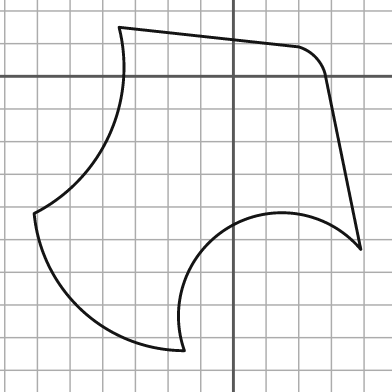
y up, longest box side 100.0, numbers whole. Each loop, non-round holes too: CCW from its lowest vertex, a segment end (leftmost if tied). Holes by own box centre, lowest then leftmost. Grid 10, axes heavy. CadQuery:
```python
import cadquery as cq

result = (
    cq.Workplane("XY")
    .moveTo(-15.0, -84.0)
    .threePointArc((-1.0, -46.0), (39.0, -53.0))
    .lineTo(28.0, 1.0)
    .threePointArc((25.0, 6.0), (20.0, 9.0))
    .lineTo(-35.0, 15.0)
    .threePointArc((-38.0, -18.0), (-61.0, -42.0))
    .threePointArc((-46.0, -72.0), (-15.0, -84.0))
    .close()
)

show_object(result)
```